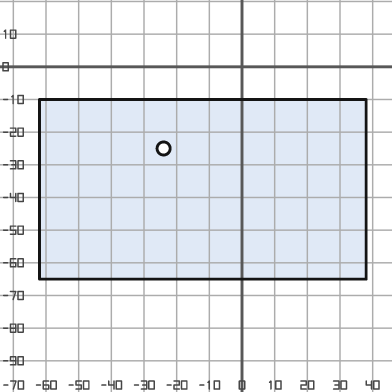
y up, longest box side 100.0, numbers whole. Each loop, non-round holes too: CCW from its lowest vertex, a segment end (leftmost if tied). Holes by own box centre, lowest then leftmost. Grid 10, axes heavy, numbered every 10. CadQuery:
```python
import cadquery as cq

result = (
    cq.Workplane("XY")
    .moveTo(-62.0, -65.0)
    .lineTo(38.0, -65.0)
    .lineTo(38.0, -10.0)
    .lineTo(-62.0, -10.0)
    .close()
    .moveTo(-24.0, -25.0)
    .circle(2.0)
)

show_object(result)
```